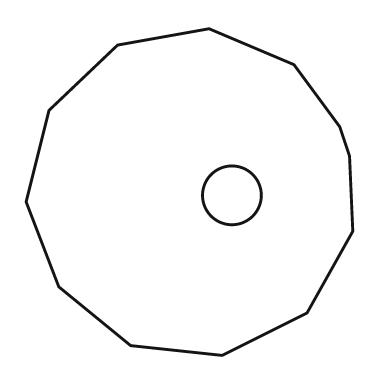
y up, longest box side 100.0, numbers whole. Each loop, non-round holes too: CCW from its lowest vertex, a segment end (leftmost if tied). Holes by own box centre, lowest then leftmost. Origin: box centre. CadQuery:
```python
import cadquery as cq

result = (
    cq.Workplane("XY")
    .moveTo(10.0, -50.0)
    .lineTo(36.0, -37.0)
    .lineTo(50.0, -12.0)
    .lineTo(49.0, 11.0)
    .lineTo(46.0, 20.0)
    .lineTo(32.0, 39.0)
    .lineTo(6.0, 50.0)
    .lineTo(-22.0, 45.0)
    .lineTo(-43.0, 25.0)
    .lineTo(-50.0, -3.0)
    .lineTo(-40.0, -29.0)
    .lineTo(-18.0, -47.0)
    .close()
    .moveTo(13.0, -1.0)
    .circle(9.0)
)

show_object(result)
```